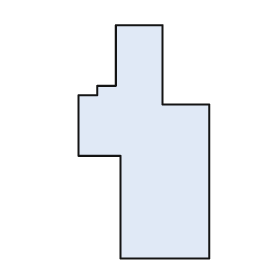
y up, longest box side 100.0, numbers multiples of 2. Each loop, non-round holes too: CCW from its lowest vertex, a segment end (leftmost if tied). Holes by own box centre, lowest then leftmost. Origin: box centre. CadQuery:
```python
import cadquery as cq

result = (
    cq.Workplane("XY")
    .moveTo(-10.0, -50.0)
    .lineTo(28.0, -50.0)
    .lineTo(28.0, 16.0)
    .lineTo(8.0, 16.0)
    .lineTo(8.0, 50.0)
    .lineTo(-12.0, 50.0)
    .lineTo(-12.0, 24.0)
    .lineTo(-20.0, 24.0)
    .lineTo(-20.0, 20.0)
    .lineTo(-28.0, 20.0)
    .lineTo(-28.0, -6.0)
    .lineTo(-10.0, -6.0)
    .close()
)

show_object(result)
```